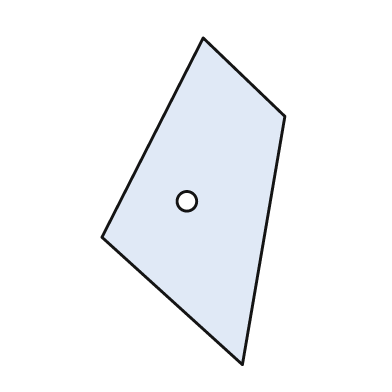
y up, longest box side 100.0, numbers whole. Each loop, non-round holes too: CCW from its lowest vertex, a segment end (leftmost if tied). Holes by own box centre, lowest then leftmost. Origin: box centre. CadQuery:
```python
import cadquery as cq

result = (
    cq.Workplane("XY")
    .moveTo(15.0, -50.0)
    .lineTo(28.0, 26.0)
    .lineTo(3.0, 50.0)
    .lineTo(-28.0, -11.0)
    .close()
    .moveTo(-2.0, 0.0)
    .circle(3.0)
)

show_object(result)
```